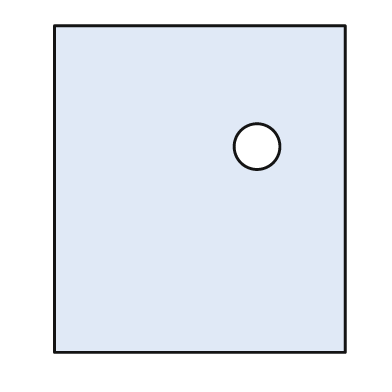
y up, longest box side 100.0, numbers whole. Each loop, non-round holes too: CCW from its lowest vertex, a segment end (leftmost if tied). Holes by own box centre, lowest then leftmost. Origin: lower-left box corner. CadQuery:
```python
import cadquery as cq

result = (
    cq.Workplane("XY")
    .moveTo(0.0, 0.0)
    .lineTo(89.0, 0.0)
    .lineTo(89.0, 100.0)
    .lineTo(0.0, 100.0)
    .close()
    .moveTo(62.0, 63.0)
    .circle(7.0)
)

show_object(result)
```